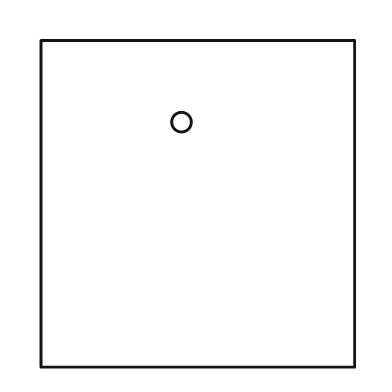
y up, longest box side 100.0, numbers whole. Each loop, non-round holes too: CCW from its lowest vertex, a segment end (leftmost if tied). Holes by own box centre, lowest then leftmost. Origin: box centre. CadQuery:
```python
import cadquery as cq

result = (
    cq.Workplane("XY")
    .moveTo(-48.0, -50.0)
    .lineTo(48.0, -50.0)
    .lineTo(48.0, 50.0)
    .lineTo(-48.0, 50.0)
    .close()
    .moveTo(-5.0, 25.0)
    .circle(3.0)
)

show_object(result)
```